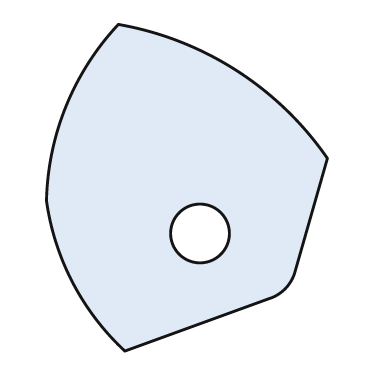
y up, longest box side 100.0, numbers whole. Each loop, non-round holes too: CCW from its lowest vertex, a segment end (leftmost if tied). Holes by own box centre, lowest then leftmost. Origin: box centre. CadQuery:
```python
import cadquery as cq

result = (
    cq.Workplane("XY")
    .moveTo(-19.0, -50.0)
    .lineTo(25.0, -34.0)
    .threePointArc((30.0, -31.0), (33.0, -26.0))
    .lineTo(43.0, 9.0)
    .threePointArc((15.0, 36.0), (-21.0, 50.0))
    .threePointArc((-37.0, 25.0), (-43.0, -4.0))
    .threePointArc((-35.0, -29.0), (-19.0, -50.0))
    .close()
    .moveTo(4.0, -14.0)
    .circle(9.0)
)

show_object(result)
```